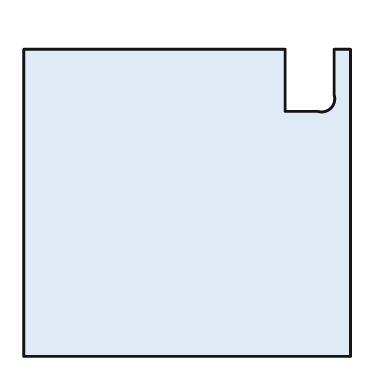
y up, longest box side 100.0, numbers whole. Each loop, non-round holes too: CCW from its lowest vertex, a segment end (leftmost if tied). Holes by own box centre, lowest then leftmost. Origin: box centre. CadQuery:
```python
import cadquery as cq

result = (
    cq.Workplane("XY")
    .moveTo(-50.0, -47.0)
    .lineTo(50.0, -47.0)
    .lineTo(50.0, 47.0)
    .lineTo(45.0, 47.0)
    .lineTo(45.0, 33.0)
    .threePointArc((44.0, 29.0), (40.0, 28.0))
    .lineTo(30.0, 28.0)
    .lineTo(30.0, 47.0)
    .lineTo(-50.0, 47.0)
    .close()
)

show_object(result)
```